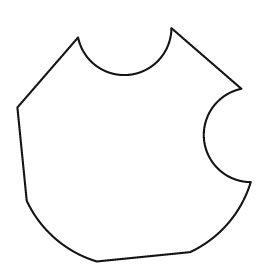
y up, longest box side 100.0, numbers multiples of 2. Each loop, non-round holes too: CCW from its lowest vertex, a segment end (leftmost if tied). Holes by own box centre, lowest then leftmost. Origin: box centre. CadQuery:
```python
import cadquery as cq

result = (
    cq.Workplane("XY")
    .moveTo(-16.0, -50.0)
    .lineTo(24.0, -46.0)
    .threePointArc((40.0, -34.0), (50.0, -16.0))
    .threePointArc((30.0, 2.0), (46.0, 24.0))
    .lineTo(16.0, 50.0)
    .threePointArc((-2.0, 30.0), (-24.0, 46.0))
    .lineTo(-50.0, 16.0)
    .lineTo(-46.0, -24.0)
    .threePointArc((-34.0, -40.0), (-16.0, -50.0))
    .close()
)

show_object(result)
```